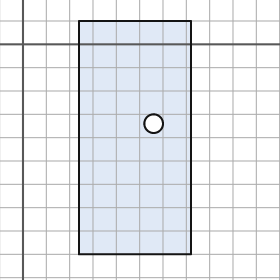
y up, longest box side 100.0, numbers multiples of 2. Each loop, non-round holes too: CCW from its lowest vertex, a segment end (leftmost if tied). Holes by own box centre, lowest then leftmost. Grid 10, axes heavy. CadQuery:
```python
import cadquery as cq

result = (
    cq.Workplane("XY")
    .moveTo(24.0, -90.0)
    .lineTo(72.0, -90.0)
    .lineTo(72.0, 10.0)
    .lineTo(24.0, 10.0)
    .close()
    .moveTo(56.0, -34.0)
    .circle(4.0)
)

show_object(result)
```